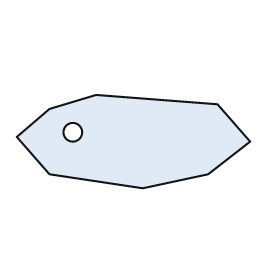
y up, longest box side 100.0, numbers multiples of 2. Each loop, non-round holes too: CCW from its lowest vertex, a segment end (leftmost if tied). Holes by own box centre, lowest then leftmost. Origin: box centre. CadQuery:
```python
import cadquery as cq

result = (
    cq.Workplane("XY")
    .moveTo(4.0, -20.0)
    .lineTo(32.0, -14.0)
    .lineTo(50.0, 0.0)
    .lineTo(36.0, 16.0)
    .lineTo(-16.0, 20.0)
    .lineTo(-36.0, 14.0)
    .lineTo(-50.0, 2.0)
    .lineTo(-36.0, -14.0)
    .close()
    .moveTo(-26.0, 4.0)
    .circle(4.0)
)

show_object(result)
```